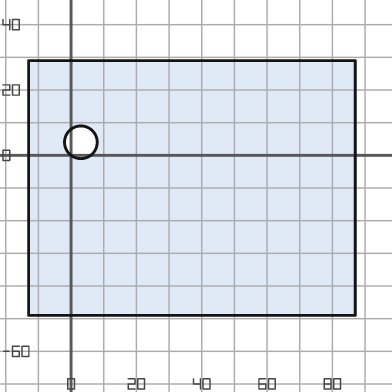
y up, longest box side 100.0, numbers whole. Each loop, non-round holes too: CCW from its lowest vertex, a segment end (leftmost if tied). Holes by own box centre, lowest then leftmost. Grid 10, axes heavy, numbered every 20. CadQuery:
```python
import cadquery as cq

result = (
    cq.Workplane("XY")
    .moveTo(-13.0, -49.0)
    .lineTo(87.0, -49.0)
    .lineTo(87.0, 29.0)
    .lineTo(-13.0, 29.0)
    .close()
    .moveTo(3.0, 4.0)
    .circle(5.0)
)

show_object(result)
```